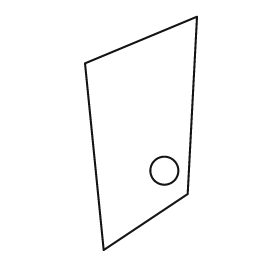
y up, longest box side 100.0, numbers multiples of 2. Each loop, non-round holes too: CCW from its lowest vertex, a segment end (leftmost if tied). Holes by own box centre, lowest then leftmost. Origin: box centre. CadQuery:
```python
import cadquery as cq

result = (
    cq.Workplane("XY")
    .moveTo(-16.0, -50.0)
    .lineTo(20.0, -26.0)
    .lineTo(24.0, 50.0)
    .lineTo(-24.0, 30.0)
    .close()
    .moveTo(10.0, -16.0)
    .circle(6.0)
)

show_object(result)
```